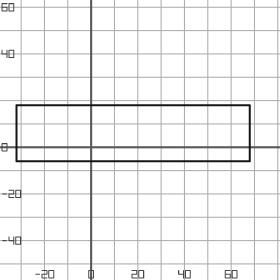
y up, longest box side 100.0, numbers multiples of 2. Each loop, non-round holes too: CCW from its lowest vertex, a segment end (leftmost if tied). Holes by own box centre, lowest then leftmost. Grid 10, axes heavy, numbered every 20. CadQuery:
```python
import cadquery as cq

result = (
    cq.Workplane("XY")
    .moveTo(-32.0, -6.0)
    .lineTo(68.0, -6.0)
    .lineTo(68.0, 18.0)
    .lineTo(-32.0, 18.0)
    .close()
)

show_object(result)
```